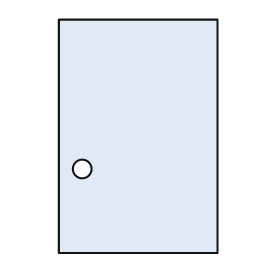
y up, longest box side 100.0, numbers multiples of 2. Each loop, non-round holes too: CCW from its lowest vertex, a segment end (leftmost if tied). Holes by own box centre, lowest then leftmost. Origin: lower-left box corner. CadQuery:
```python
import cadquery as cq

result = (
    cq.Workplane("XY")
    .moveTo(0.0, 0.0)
    .lineTo(68.0, 0.0)
    .lineTo(68.0, 100.0)
    .lineTo(0.0, 100.0)
    .close()
    .moveTo(10.0, 36.0)
    .circle(4.0)
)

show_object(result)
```